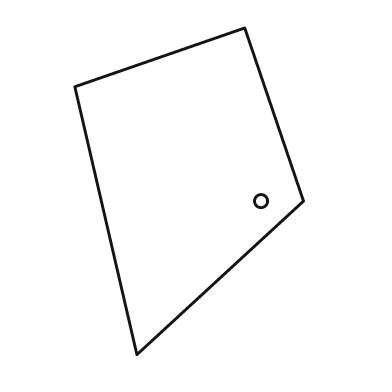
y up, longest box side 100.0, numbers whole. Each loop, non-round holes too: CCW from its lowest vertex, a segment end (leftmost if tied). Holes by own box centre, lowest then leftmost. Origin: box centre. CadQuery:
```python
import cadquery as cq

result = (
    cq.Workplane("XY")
    .moveTo(-16.0, -50.0)
    .lineTo(35.0, -3.0)
    .lineTo(17.0, 50.0)
    .lineTo(-35.0, 32.0)
    .close()
    .moveTo(22.0, -3.0)
    .circle(2.0)
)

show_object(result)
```